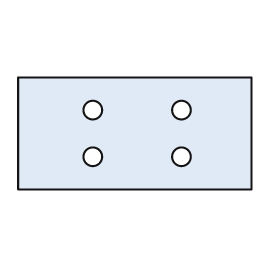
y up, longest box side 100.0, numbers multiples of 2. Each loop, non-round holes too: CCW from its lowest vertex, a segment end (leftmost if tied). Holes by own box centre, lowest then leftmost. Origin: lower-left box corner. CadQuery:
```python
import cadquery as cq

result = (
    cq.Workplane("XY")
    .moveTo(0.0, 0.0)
    .lineTo(100.0, 0.0)
    .lineTo(100.0, 48.0)
    .lineTo(0.0, 48.0)
    .close()
    .moveTo(32.0, 14.0)
    .circle(4.0)
    .moveTo(70.0, 14.0)
    .circle(4.0)
    .moveTo(32.0, 34.0)
    .circle(4.0)
    .moveTo(70.0, 34.0)
    .circle(4.0)
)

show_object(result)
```